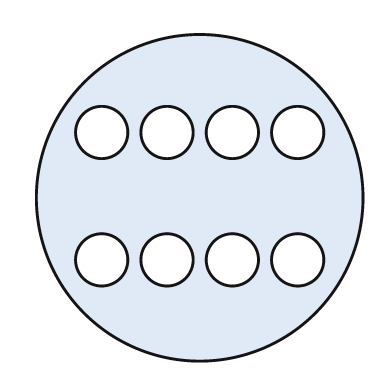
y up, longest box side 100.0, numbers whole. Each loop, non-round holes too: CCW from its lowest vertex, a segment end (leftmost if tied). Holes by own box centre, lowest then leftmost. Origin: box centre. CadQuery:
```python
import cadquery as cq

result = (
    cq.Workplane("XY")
    .moveTo(0.0, 0.0)
    .circle(50.0)
    .moveTo(-30.0, -19.0)
    .circle(8.0)
    .moveTo(-10.0, -19.0)
    .circle(8.0)
    .moveTo(10.0, -19.0)
    .circle(8.0)
    .moveTo(30.0, -19.0)
    .circle(8.0)
    .moveTo(-30.0, 20.0)
    .circle(8.0)
    .moveTo(-10.0, 20.0)
    .circle(8.0)
    .moveTo(10.0, 20.0)
    .circle(8.0)
    .moveTo(30.0, 20.0)
    .circle(8.0)
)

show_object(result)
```